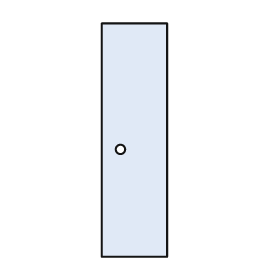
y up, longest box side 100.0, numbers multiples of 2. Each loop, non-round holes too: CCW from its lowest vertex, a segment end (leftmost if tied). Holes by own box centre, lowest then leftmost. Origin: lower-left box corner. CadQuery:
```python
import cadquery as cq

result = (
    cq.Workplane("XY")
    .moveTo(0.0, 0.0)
    .lineTo(28.0, 0.0)
    .lineTo(28.0, 100.0)
    .lineTo(0.0, 100.0)
    .close()
    .moveTo(8.0, 46.0)
    .circle(2.0)
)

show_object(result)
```